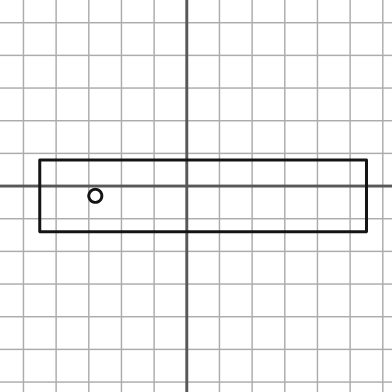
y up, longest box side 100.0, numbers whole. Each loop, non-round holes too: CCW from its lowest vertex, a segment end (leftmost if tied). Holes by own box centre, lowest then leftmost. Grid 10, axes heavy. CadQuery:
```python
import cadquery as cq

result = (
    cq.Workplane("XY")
    .moveTo(-45.0, -14.0)
    .lineTo(55.0, -14.0)
    .lineTo(55.0, 8.0)
    .lineTo(-45.0, 8.0)
    .close()
    .moveTo(-28.0, -3.0)
    .circle(2.0)
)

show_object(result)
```